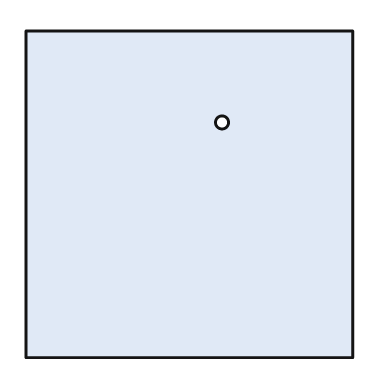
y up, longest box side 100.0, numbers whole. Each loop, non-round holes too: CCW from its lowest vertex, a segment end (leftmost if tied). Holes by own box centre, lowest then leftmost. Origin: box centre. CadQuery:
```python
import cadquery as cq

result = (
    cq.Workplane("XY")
    .moveTo(-50.0, -50.0)
    .lineTo(50.0, -50.0)
    .lineTo(50.0, 50.0)
    .lineTo(-50.0, 50.0)
    .close()
    .moveTo(10.0, 22.0)
    .circle(2.0)
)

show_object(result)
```